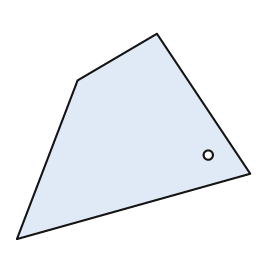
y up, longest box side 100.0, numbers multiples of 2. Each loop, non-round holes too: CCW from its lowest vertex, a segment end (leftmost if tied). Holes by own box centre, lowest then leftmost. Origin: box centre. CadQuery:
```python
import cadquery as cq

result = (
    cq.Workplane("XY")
    .moveTo(-50.0, -44.0)
    .lineTo(50.0, -16.0)
    .lineTo(10.0, 44.0)
    .lineTo(-24.0, 24.0)
    .close()
    .moveTo(32.0, -8.0)
    .circle(2.0)
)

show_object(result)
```